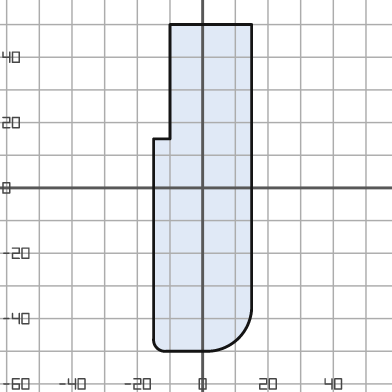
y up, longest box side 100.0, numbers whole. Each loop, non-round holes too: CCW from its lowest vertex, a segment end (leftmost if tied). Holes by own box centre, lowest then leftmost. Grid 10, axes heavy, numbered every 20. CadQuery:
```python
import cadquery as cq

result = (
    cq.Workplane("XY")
    .moveTo(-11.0, -50.0)
    .lineTo(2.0, -50.0)
    .threePointArc((11.0, -46.0), (15.0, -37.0))
    .lineTo(15.0, 50.0)
    .lineTo(-10.0, 50.0)
    .lineTo(-10.0, 15.0)
    .lineTo(-15.0, 15.0)
    .lineTo(-15.0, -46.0)
    .threePointArc((-14.0, -49.0), (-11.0, -50.0))
    .close()
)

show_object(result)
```